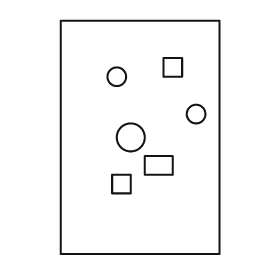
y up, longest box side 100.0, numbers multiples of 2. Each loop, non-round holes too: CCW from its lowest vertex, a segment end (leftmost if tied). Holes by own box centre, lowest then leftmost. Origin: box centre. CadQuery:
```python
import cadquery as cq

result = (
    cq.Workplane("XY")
    .moveTo(-34.0, -50.0)
    .lineTo(34.0, -50.0)
    .lineTo(34.0, 50.0)
    .lineTo(-34.0, 50.0)
    .close()
    .moveTo(-12.0, -24.0)
    .lineTo(-4.0, -24.0)
    .lineTo(-4.0, -16.0)
    .lineTo(-12.0, -16.0)
    .close()
    .moveTo(2.0, -16.0)
    .lineTo(14.0, -16.0)
    .lineTo(14.0, -8.0)
    .lineTo(2.0, -8.0)
    .close()
    .moveTo(-4.0, 0.0)
    .circle(6.0)
    .moveTo(24.0, 10.0)
    .circle(4.0)
    .moveTo(-10.0, 26.0)
    .circle(4.0)
    .moveTo(10.0, 26.0)
    .lineTo(18.0, 26.0)
    .lineTo(18.0, 34.0)
    .lineTo(10.0, 34.0)
    .close()
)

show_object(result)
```